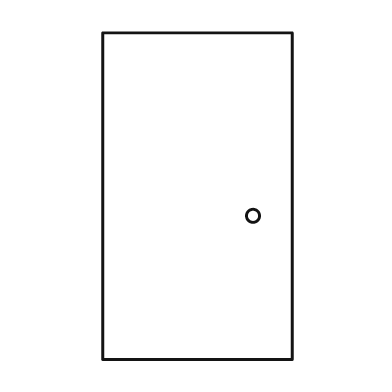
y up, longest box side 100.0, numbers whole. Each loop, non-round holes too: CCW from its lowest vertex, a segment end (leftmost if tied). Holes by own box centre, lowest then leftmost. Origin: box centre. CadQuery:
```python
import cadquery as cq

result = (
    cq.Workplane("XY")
    .moveTo(-29.0, -50.0)
    .lineTo(29.0, -50.0)
    .lineTo(29.0, 50.0)
    .lineTo(-29.0, 50.0)
    .close()
    .moveTo(17.0, -6.0)
    .circle(2.0)
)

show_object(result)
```